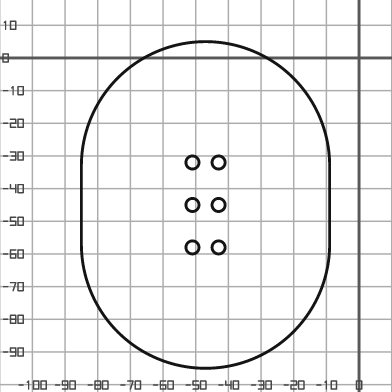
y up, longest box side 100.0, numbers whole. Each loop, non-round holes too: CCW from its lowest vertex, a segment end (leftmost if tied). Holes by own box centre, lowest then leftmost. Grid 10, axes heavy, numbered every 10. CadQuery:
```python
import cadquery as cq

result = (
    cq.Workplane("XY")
    .moveTo(-85.0, -57.0)
    .threePointArc((-47.0, -95.0), (-9.0, -57.0))
    .lineTo(-9.0, -33.0)
    .threePointArc((-47.0, 5.0), (-85.0, -33.0))
    .close()
    .moveTo(-51.0, -58.0)
    .circle(2.0)
    .moveTo(-43.0, -58.0)
    .circle(2.0)
    .moveTo(-51.0, -45.0)
    .circle(2.0)
    .moveTo(-43.0, -45.0)
    .circle(2.0)
    .moveTo(-51.0, -32.0)
    .circle(2.0)
    .moveTo(-43.0, -32.0)
    .circle(2.0)
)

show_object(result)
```